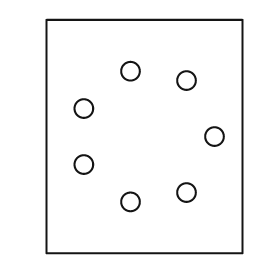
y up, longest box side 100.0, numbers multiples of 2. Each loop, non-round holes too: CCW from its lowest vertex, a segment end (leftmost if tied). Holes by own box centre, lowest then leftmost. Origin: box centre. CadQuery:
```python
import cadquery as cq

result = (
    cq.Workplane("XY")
    .moveTo(-42.0, -50.0)
    .lineTo(42.0, -50.0)
    .lineTo(42.0, 50.0)
    .lineTo(-42.0, 50.0)
    .close()
    .moveTo(-6.0, -28.0)
    .circle(4.0)
    .moveTo(18.0, -24.0)
    .circle(4.0)
    .moveTo(-26.0, -12.0)
    .circle(4.0)
    .moveTo(30.0, 0.0)
    .circle(4.0)
    .moveTo(-26.0, 12.0)
    .circle(4.0)
    .moveTo(18.0, 24.0)
    .circle(4.0)
    .moveTo(-6.0, 28.0)
    .circle(4.0)
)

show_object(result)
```